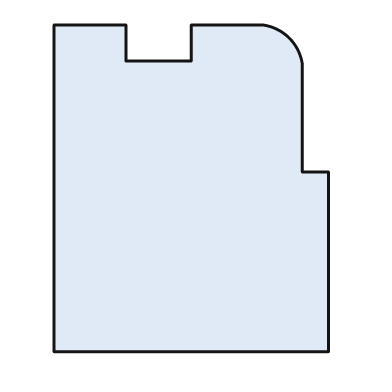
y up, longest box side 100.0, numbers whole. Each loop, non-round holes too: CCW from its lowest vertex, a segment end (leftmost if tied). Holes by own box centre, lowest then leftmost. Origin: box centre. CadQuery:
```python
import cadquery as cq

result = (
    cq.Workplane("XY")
    .moveTo(-42.0, -50.0)
    .lineTo(42.0, -50.0)
    .lineTo(42.0, 5.0)
    .lineTo(34.0, 5.0)
    .lineTo(34.0, 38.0)
    .threePointArc((30.0, 46.0), (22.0, 50.0))
    .lineTo(0.0, 50.0)
    .lineTo(0.0, 39.0)
    .lineTo(-20.0, 39.0)
    .lineTo(-20.0, 50.0)
    .lineTo(-42.0, 50.0)
    .close()
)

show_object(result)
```